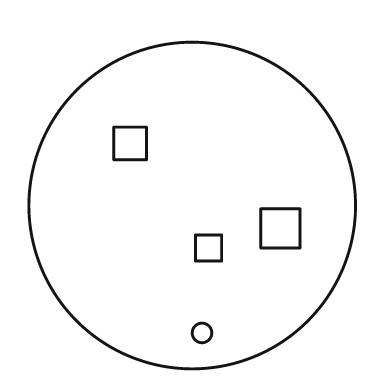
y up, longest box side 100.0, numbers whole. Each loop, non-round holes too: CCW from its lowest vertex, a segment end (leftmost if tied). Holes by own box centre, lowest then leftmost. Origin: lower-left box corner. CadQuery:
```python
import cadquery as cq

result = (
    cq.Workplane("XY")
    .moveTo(50.0, 50.0)
    .circle(50.0)
    .moveTo(53.0, 11.0)
    .circle(3.0)
    .moveTo(51.0, 33.0)
    .lineTo(59.0, 33.0)
    .lineTo(59.0, 41.0)
    .lineTo(51.0, 41.0)
    .close()
    .moveTo(71.0, 37.0)
    .lineTo(83.0, 37.0)
    .lineTo(83.0, 49.0)
    .lineTo(71.0, 49.0)
    .close()
    .moveTo(26.0, 64.0)
    .lineTo(36.0, 64.0)
    .lineTo(36.0, 74.0)
    .lineTo(26.0, 74.0)
    .close()
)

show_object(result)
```